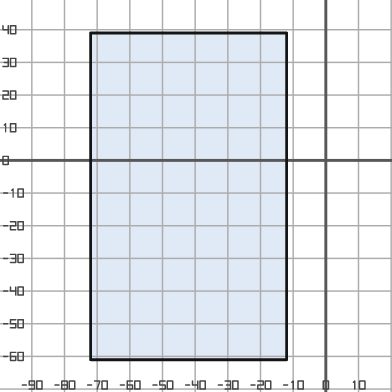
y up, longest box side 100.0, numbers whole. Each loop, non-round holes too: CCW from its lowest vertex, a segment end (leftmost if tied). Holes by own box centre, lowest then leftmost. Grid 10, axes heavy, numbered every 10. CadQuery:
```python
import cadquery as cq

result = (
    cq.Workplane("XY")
    .moveTo(-72.0, -61.0)
    .lineTo(-12.0, -61.0)
    .lineTo(-12.0, 39.0)
    .lineTo(-72.0, 39.0)
    .close()
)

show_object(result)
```